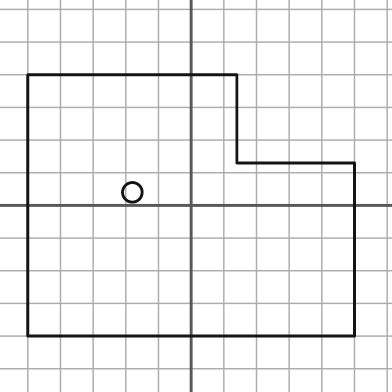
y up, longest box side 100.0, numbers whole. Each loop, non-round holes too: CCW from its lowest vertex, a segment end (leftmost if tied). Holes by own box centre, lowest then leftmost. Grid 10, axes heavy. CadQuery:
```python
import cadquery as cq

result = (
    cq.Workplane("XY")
    .moveTo(-50.0, -40.0)
    .lineTo(50.0, -40.0)
    .lineTo(50.0, 13.0)
    .lineTo(14.0, 13.0)
    .lineTo(14.0, 40.0)
    .lineTo(-50.0, 40.0)
    .close()
    .moveTo(-18.0, 4.0)
    .circle(3.0)
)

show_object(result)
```